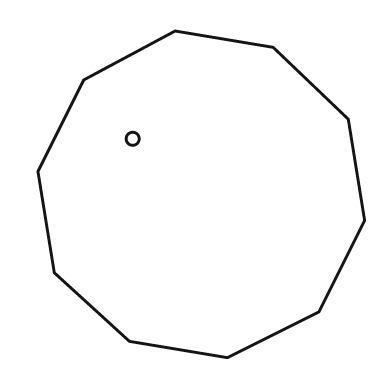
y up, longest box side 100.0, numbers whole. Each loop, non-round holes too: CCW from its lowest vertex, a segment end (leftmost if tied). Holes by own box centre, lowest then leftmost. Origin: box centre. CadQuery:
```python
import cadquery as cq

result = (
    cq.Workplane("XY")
    .moveTo(8.0, -50.0)
    .lineTo(36.0, -36.0)
    .lineTo(50.0, -8.0)
    .lineTo(45.0, 23.0)
    .lineTo(22.0, 45.0)
    .lineTo(-8.0, 50.0)
    .lineTo(-36.0, 35.0)
    .lineTo(-50.0, 7.0)
    .lineTo(-45.0, -24.0)
    .lineTo(-22.0, -45.0)
    .close()
    .moveTo(-21.0, 17.0)
    .circle(2.0)
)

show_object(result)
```